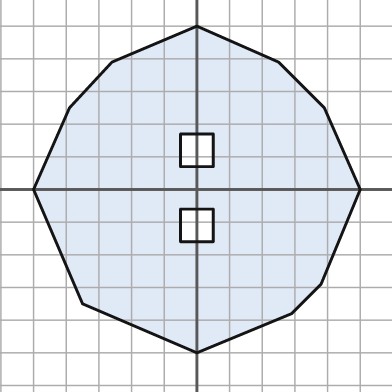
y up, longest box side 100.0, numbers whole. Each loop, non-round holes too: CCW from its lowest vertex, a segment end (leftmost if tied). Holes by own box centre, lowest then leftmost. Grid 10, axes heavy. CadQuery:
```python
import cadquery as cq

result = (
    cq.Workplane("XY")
    .moveTo(0.0, -50.0)
    .lineTo(29.0, -38.0)
    .lineTo(38.0, -29.0)
    .lineTo(50.0, 0.0)
    .lineTo(39.0, 25.0)
    .lineTo(25.0, 39.0)
    .lineTo(0.0, 50.0)
    .lineTo(-26.0, 39.0)
    .lineTo(-39.0, 25.0)
    .lineTo(-50.0, 0.0)
    .lineTo(-35.0, -35.0)
    .close()
    .moveTo(-5.0, -16.0)
    .lineTo(5.0, -16.0)
    .lineTo(5.0, -6.0)
    .lineTo(-5.0, -6.0)
    .close()
    .moveTo(-5.0, 7.0)
    .lineTo(5.0, 7.0)
    .lineTo(5.0, 17.0)
    .lineTo(-5.0, 17.0)
    .close()
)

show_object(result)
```